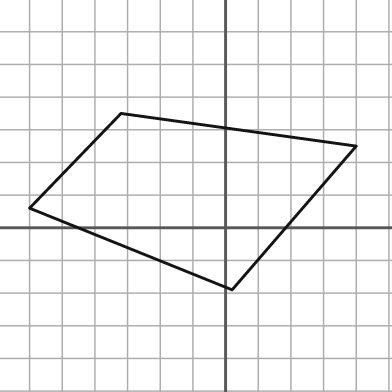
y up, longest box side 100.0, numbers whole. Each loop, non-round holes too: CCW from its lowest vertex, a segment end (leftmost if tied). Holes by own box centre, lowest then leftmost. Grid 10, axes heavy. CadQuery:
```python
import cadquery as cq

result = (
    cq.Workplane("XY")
    .moveTo(2.0, -19.0)
    .lineTo(40.0, 25.0)
    .lineTo(-32.0, 35.0)
    .lineTo(-60.0, 6.0)
    .close()
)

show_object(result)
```